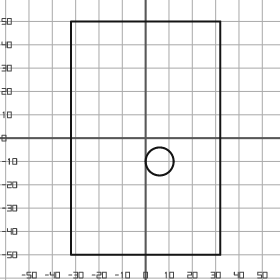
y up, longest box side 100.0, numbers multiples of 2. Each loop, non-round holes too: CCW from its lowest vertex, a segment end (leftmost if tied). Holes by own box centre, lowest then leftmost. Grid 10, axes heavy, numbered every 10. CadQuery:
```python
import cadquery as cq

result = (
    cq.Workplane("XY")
    .moveTo(-32.0, -50.0)
    .lineTo(32.0, -50.0)
    .lineTo(32.0, 50.0)
    .lineTo(-32.0, 50.0)
    .close()
    .moveTo(6.0, -10.0)
    .circle(6.0)
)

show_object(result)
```